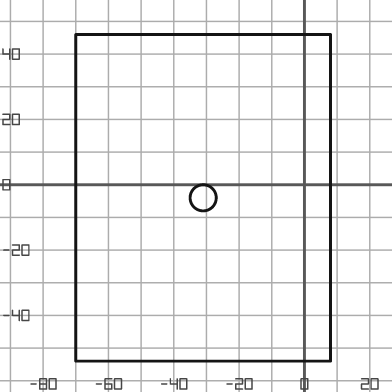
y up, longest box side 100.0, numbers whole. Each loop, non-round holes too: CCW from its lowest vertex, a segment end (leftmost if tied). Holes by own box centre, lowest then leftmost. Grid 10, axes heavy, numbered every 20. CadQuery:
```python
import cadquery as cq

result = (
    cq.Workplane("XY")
    .moveTo(-70.0, -54.0)
    .lineTo(8.0, -54.0)
    .lineTo(8.0, 46.0)
    .lineTo(-70.0, 46.0)
    .close()
    .moveTo(-31.0, -4.0)
    .circle(4.0)
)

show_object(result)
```